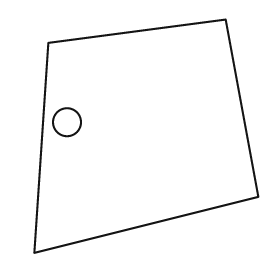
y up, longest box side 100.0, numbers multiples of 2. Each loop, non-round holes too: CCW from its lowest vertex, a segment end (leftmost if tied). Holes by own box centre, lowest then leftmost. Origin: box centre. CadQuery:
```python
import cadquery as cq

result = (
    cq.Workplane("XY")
    .moveTo(-48.0, -50.0)
    .lineTo(48.0, -26.0)
    .lineTo(34.0, 50.0)
    .lineTo(-42.0, 40.0)
    .close()
    .moveTo(-34.0, 6.0)
    .circle(6.0)
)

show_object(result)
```